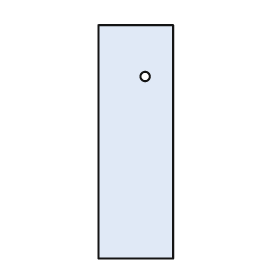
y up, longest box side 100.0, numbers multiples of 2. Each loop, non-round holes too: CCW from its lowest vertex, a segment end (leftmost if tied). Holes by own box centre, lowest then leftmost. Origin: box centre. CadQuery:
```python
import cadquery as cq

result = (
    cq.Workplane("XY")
    .moveTo(-16.0, -50.0)
    .lineTo(16.0, -50.0)
    .lineTo(16.0, 50.0)
    .lineTo(-16.0, 50.0)
    .close()
    .moveTo(4.0, 28.0)
    .circle(2.0)
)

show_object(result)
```